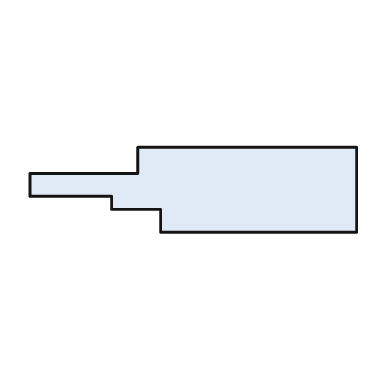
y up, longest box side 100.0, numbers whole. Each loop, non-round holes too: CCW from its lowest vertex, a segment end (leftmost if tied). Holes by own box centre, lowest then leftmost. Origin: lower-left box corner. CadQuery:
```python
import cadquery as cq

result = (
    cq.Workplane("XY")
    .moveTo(40.0, 0.0)
    .lineTo(100.0, 0.0)
    .lineTo(100.0, 26.0)
    .lineTo(33.0, 26.0)
    .lineTo(33.0, 18.0)
    .lineTo(0.0, 18.0)
    .lineTo(0.0, 11.0)
    .lineTo(25.0, 11.0)
    .lineTo(25.0, 7.0)
    .lineTo(40.0, 7.0)
    .close()
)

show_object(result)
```